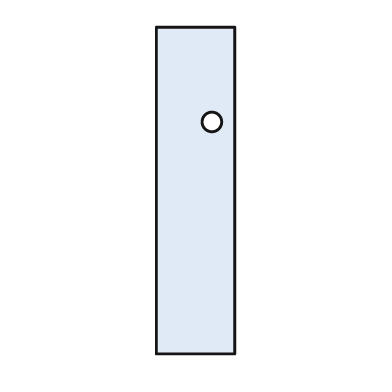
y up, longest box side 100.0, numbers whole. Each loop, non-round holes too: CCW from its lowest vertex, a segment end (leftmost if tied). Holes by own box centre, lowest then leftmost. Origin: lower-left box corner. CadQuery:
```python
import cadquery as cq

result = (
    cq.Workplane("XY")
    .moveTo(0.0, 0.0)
    .lineTo(24.0, 0.0)
    .lineTo(24.0, 100.0)
    .lineTo(0.0, 100.0)
    .close()
    .moveTo(17.0, 71.0)
    .circle(3.0)
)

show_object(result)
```